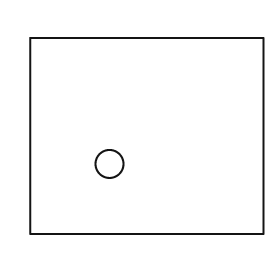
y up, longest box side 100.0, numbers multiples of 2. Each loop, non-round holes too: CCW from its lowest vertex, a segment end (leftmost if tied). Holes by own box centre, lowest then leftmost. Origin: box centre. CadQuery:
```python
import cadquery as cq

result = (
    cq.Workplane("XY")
    .moveTo(-50.0, -42.0)
    .lineTo(50.0, -42.0)
    .lineTo(50.0, 42.0)
    .lineTo(-50.0, 42.0)
    .close()
    .moveTo(-16.0, -12.0)
    .circle(6.0)
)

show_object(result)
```